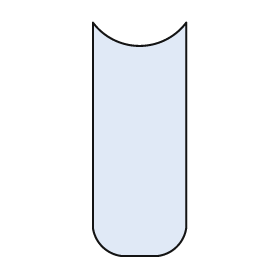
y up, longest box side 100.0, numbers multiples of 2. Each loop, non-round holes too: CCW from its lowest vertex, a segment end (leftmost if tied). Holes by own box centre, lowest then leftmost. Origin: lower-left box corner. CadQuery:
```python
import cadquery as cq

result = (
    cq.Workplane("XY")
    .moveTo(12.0, 0.0)
    .lineTo(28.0, 0.0)
    .threePointArc((36.0, 4.0), (40.0, 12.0))
    .lineTo(40.0, 100.0)
    .threePointArc((20.0, 90.0), (0.0, 100.0))
    .lineTo(0.0, 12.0)
    .threePointArc((4.0, 4.0), (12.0, 0.0))
    .close()
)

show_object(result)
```